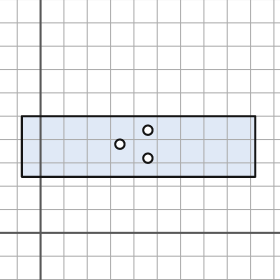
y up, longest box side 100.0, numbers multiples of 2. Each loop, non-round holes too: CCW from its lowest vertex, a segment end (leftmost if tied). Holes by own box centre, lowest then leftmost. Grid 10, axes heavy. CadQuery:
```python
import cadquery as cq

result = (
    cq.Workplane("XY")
    .moveTo(-8.0, 24.0)
    .lineTo(92.0, 24.0)
    .lineTo(92.0, 50.0)
    .lineTo(-8.0, 50.0)
    .close()
    .moveTo(46.0, 32.0)
    .circle(2.0)
    .moveTo(34.0, 38.0)
    .circle(2.0)
    .moveTo(46.0, 44.0)
    .circle(2.0)
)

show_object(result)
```